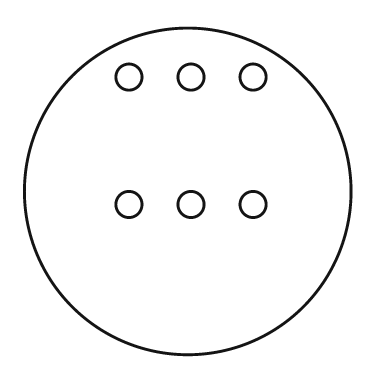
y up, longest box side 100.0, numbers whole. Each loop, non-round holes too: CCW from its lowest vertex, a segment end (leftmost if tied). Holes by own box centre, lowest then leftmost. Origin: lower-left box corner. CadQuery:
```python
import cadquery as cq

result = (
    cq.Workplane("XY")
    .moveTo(50.0, 50.0)
    .circle(50.0)
    .moveTo(32.0, 46.0)
    .circle(4.0)
    .moveTo(51.0, 46.0)
    .circle(4.0)
    .moveTo(70.0, 46.0)
    .circle(4.0)
    .moveTo(32.0, 85.0)
    .circle(4.0)
    .moveTo(51.0, 85.0)
    .circle(4.0)
    .moveTo(70.0, 85.0)
    .circle(4.0)
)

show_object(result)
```